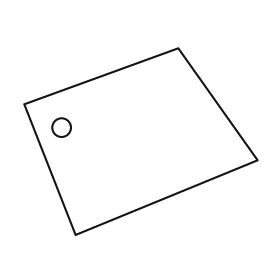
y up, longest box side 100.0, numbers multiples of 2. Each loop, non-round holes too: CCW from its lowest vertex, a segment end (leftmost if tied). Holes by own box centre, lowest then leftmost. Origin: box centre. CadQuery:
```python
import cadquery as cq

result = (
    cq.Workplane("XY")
    .moveTo(-28.0, -40.0)
    .lineTo(50.0, -8.0)
    .lineTo(16.0, 40.0)
    .lineTo(-50.0, 16.0)
    .close()
    .moveTo(-34.0, 6.0)
    .circle(4.0)
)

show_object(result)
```